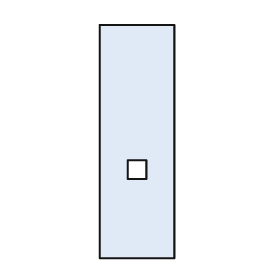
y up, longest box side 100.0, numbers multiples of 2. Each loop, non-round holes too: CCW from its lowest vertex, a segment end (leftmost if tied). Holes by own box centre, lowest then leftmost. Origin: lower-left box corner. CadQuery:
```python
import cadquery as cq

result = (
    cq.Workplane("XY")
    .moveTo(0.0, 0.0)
    .lineTo(32.0, 0.0)
    .lineTo(32.0, 100.0)
    .lineTo(0.0, 100.0)
    .close()
    .moveTo(12.0, 34.0)
    .lineTo(20.0, 34.0)
    .lineTo(20.0, 42.0)
    .lineTo(12.0, 42.0)
    .close()
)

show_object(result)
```